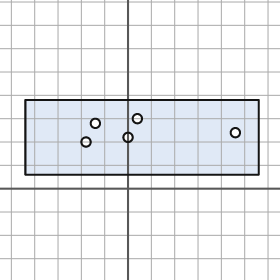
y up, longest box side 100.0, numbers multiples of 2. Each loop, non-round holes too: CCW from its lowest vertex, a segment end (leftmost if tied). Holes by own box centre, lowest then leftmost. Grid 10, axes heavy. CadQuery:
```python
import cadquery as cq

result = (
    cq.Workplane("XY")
    .moveTo(-44.0, 6.0)
    .lineTo(56.0, 6.0)
    .lineTo(56.0, 38.0)
    .lineTo(-44.0, 38.0)
    .close()
    .moveTo(-18.0, 20.0)
    .circle(2.0)
    .moveTo(0.0, 22.0)
    .circle(2.0)
    .moveTo(46.0, 24.0)
    .circle(2.0)
    .moveTo(-14.0, 28.0)
    .circle(2.0)
    .moveTo(4.0, 30.0)
    .circle(2.0)
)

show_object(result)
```